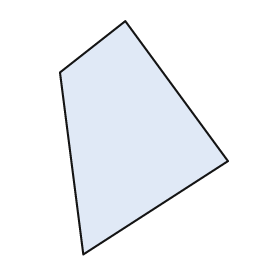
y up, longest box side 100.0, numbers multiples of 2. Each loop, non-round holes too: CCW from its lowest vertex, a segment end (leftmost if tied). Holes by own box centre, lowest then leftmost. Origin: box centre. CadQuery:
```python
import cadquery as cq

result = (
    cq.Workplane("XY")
    .moveTo(-26.0, -50.0)
    .lineTo(36.0, -10.0)
    .lineTo(-8.0, 50.0)
    .lineTo(-36.0, 28.0)
    .close()
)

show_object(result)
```